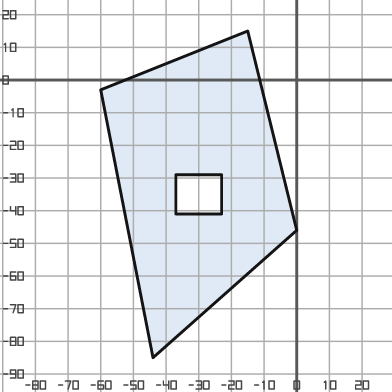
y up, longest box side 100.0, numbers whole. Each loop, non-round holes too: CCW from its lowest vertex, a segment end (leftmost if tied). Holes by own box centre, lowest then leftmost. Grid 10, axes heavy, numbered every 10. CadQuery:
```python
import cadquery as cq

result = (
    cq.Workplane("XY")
    .moveTo(-44.0, -85.0)
    .lineTo(0.0, -46.0)
    .lineTo(-15.0, 15.0)
    .lineTo(-60.0, -3.0)
    .close()
    .moveTo(-37.0, -41.0)
    .lineTo(-23.0, -41.0)
    .lineTo(-23.0, -29.0)
    .lineTo(-37.0, -29.0)
    .close()
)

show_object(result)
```